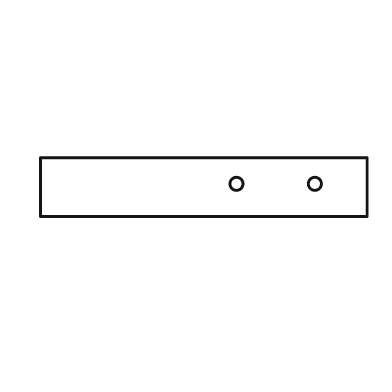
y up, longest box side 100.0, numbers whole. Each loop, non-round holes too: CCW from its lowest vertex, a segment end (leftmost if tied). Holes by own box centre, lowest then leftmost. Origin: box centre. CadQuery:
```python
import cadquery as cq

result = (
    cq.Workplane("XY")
    .moveTo(-50.0, -9.0)
    .lineTo(50.0, -9.0)
    .lineTo(50.0, 9.0)
    .lineTo(-50.0, 9.0)
    .close()
    .moveTo(10.0, 1.0)
    .circle(2.0)
    .moveTo(34.0, 1.0)
    .circle(2.0)
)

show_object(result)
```